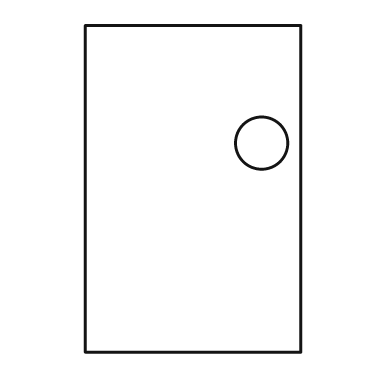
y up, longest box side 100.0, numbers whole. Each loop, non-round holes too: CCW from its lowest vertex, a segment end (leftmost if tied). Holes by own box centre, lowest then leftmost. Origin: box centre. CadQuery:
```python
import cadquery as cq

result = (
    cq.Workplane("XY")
    .moveTo(-33.0, -50.0)
    .lineTo(33.0, -50.0)
    .lineTo(33.0, 50.0)
    .lineTo(-33.0, 50.0)
    .close()
    .moveTo(21.0, 14.0)
    .circle(8.0)
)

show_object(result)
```